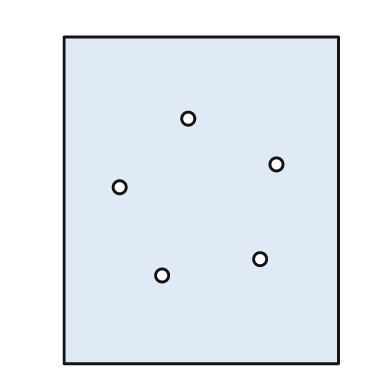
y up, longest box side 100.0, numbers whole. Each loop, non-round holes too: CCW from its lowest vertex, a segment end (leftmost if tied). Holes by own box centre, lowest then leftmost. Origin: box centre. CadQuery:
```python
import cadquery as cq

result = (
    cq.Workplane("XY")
    .moveTo(-42.0, -50.0)
    .lineTo(42.0, -50.0)
    .lineTo(42.0, 50.0)
    .lineTo(-42.0, 50.0)
    .close()
    .moveTo(-12.0, -23.0)
    .circle(2.0)
    .moveTo(18.0, -18.0)
    .circle(2.0)
    .moveTo(-25.0, 4.0)
    .circle(2.0)
    .moveTo(23.0, 11.0)
    .circle(2.0)
    .moveTo(-4.0, 25.0)
    .circle(2.0)
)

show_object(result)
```